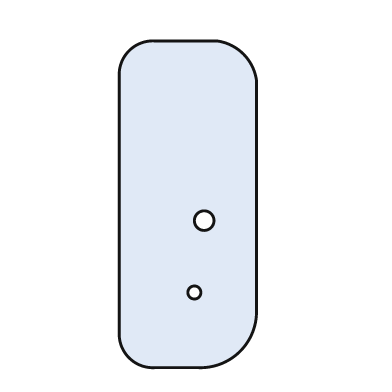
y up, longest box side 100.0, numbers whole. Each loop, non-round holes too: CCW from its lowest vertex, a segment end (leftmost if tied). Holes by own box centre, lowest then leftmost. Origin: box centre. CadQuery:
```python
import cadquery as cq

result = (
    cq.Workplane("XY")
    .moveTo(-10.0, -50.0)
    .lineTo(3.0, -50.0)
    .threePointArc((16.0, -45.0), (21.0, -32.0))
    .lineTo(21.0, 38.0)
    .threePointArc((17.0, 46.0), (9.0, 50.0))
    .lineTo(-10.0, 50.0)
    .threePointArc((-18.0, 47.0), (-21.0, 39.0))
    .lineTo(-21.0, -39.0)
    .threePointArc((-18.0, -47.0), (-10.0, -50.0))
    .close()
    .moveTo(2.0, -27.0)
    .circle(2.0)
    .moveTo(5.0, -5.0)
    .circle(3.0)
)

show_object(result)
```